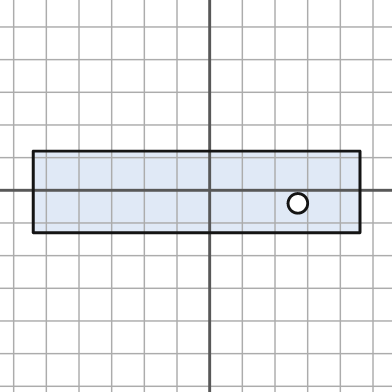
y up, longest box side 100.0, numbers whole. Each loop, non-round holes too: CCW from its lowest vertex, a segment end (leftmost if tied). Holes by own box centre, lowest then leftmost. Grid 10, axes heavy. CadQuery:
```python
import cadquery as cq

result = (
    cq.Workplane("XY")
    .moveTo(-54.0, -13.0)
    .lineTo(46.0, -13.0)
    .lineTo(46.0, 12.0)
    .lineTo(-54.0, 12.0)
    .close()
    .moveTo(27.0, -4.0)
    .circle(3.0)
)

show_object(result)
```